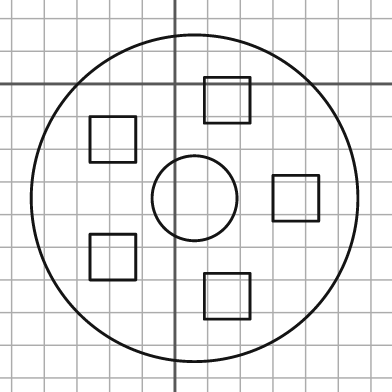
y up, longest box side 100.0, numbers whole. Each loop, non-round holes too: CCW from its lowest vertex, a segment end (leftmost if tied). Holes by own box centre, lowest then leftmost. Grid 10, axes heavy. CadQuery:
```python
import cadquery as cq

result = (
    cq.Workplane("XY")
    .moveTo(6.0, -35.0)
    .circle(50.0)
    .moveTo(9.0, -72.0)
    .lineTo(23.0, -72.0)
    .lineTo(23.0, -58.0)
    .lineTo(9.0, -58.0)
    .close()
    .moveTo(-26.0, -60.0)
    .lineTo(-12.0, -60.0)
    .lineTo(-12.0, -46.0)
    .lineTo(-26.0, -46.0)
    .close()
    .moveTo(6.0, -35.0)
    .circle(13.0)
    .moveTo(30.0, -42.0)
    .lineTo(44.0, -42.0)
    .lineTo(44.0, -28.0)
    .lineTo(30.0, -28.0)
    .close()
    .moveTo(-26.0, -24.0)
    .lineTo(-12.0, -24.0)
    .lineTo(-12.0, -10.0)
    .lineTo(-26.0, -10.0)
    .close()
    .moveTo(9.0, -12.0)
    .lineTo(23.0, -12.0)
    .lineTo(23.0, 2.0)
    .lineTo(9.0, 2.0)
    .close()
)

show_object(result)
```